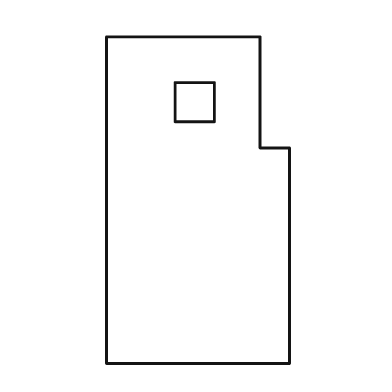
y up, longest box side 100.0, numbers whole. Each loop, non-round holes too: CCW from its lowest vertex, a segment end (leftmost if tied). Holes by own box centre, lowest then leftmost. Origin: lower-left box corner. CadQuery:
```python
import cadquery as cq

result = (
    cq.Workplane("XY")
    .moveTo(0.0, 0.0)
    .lineTo(56.0, 0.0)
    .lineTo(56.0, 66.0)
    .lineTo(47.0, 66.0)
    .lineTo(47.0, 100.0)
    .lineTo(0.0, 100.0)
    .close()
    .moveTo(21.0, 74.0)
    .lineTo(33.0, 74.0)
    .lineTo(33.0, 86.0)
    .lineTo(21.0, 86.0)
    .close()
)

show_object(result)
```